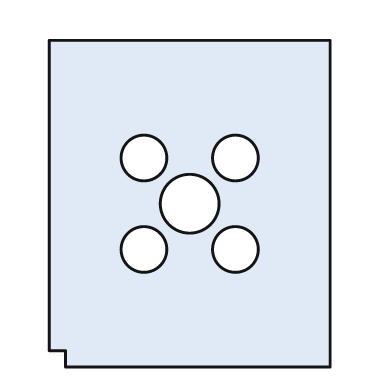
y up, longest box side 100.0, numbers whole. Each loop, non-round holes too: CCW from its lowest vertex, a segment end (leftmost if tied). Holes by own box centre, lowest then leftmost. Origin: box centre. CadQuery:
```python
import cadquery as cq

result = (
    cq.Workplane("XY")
    .moveTo(-38.0, -50.0)
    .lineTo(43.0, -50.0)
    .lineTo(43.0, 50.0)
    .lineTo(-43.0, 50.0)
    .lineTo(-43.0, -45.0)
    .lineTo(-38.0, -45.0)
    .close()
    .moveTo(-14.0, -14.0)
    .circle(7.0)
    .moveTo(14.0, -14.0)
    .circle(7.0)
    .moveTo(0.0, 0.0)
    .circle(9.0)
    .moveTo(-14.0, 14.0)
    .circle(7.0)
    .moveTo(14.0, 14.0)
    .circle(7.0)
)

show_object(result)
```